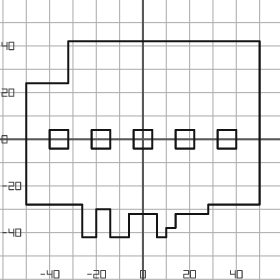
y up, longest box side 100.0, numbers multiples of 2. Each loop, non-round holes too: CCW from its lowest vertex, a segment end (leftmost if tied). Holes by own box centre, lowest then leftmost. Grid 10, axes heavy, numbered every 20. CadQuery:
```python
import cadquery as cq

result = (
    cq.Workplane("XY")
    .moveTo(-26.0, -42.0)
    .lineTo(-20.0, -42.0)
    .lineTo(-20.0, -30.0)
    .lineTo(-14.0, -30.0)
    .lineTo(-14.0, -42.0)
    .lineTo(-6.0, -42.0)
    .lineTo(-6.0, -32.0)
    .lineTo(6.0, -32.0)
    .lineTo(6.0, -42.0)
    .lineTo(10.0, -42.0)
    .lineTo(10.0, -38.0)
    .lineTo(14.0, -38.0)
    .lineTo(14.0, -32.0)
    .lineTo(28.0, -32.0)
    .lineTo(28.0, -28.0)
    .lineTo(50.0, -28.0)
    .lineTo(50.0, 42.0)
    .lineTo(-32.0, 42.0)
    .lineTo(-32.0, 24.0)
    .lineTo(-50.0, 24.0)
    .lineTo(-50.0, -28.0)
    .lineTo(-26.0, -28.0)
    .close()
    .moveTo(-40.0, -4.0)
    .lineTo(-32.0, -4.0)
    .lineTo(-32.0, 4.0)
    .lineTo(-40.0, 4.0)
    .close()
    .moveTo(-22.0, -4.0)
    .lineTo(-14.0, -4.0)
    .lineTo(-14.0, 4.0)
    .lineTo(-22.0, 4.0)
    .close()
    .moveTo(-4.0, -4.0)
    .lineTo(4.0, -4.0)
    .lineTo(4.0, 4.0)
    .lineTo(-4.0, 4.0)
    .close()
    .moveTo(14.0, -4.0)
    .lineTo(22.0, -4.0)
    .lineTo(22.0, 4.0)
    .lineTo(14.0, 4.0)
    .close()
    .moveTo(32.0, -4.0)
    .lineTo(40.0, -4.0)
    .lineTo(40.0, 4.0)
    .lineTo(32.0, 4.0)
    .close()
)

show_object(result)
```